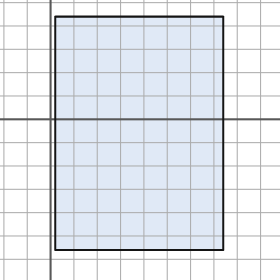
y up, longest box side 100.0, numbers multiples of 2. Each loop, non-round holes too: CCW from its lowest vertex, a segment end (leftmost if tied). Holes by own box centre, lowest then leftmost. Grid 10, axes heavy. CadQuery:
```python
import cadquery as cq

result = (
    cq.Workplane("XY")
    .moveTo(2.0, -56.0)
    .lineTo(74.0, -56.0)
    .lineTo(74.0, 44.0)
    .lineTo(2.0, 44.0)
    .close()
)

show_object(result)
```